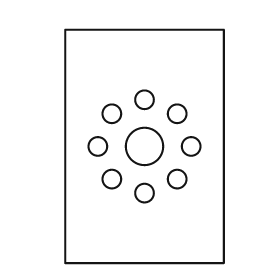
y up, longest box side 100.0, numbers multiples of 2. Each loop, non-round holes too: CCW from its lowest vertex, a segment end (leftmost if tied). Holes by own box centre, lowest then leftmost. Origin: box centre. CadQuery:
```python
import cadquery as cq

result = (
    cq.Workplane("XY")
    .moveTo(-34.0, -50.0)
    .lineTo(34.0, -50.0)
    .lineTo(34.0, 50.0)
    .lineTo(-34.0, 50.0)
    .close()
    .moveTo(0.0, -20.0)
    .circle(4.0)
    .moveTo(-14.0, -14.0)
    .circle(4.0)
    .moveTo(14.0, -14.0)
    .circle(4.0)
    .moveTo(-20.0, 0.0)
    .circle(4.0)
    .moveTo(0.0, 0.0)
    .circle(8.0)
    .moveTo(20.0, 0.0)
    .circle(4.0)
    .moveTo(-14.0, 14.0)
    .circle(4.0)
    .moveTo(14.0, 14.0)
    .circle(4.0)
    .moveTo(0.0, 20.0)
    .circle(4.0)
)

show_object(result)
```